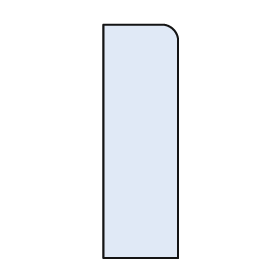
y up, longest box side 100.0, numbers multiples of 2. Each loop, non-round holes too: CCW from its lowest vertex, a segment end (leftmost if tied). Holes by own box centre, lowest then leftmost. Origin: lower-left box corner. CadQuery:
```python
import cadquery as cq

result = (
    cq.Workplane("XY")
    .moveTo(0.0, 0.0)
    .lineTo(32.0, 0.0)
    .lineTo(32.0, 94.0)
    .threePointArc((30.0, 98.0), (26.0, 100.0))
    .lineTo(0.0, 100.0)
    .close()
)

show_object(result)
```